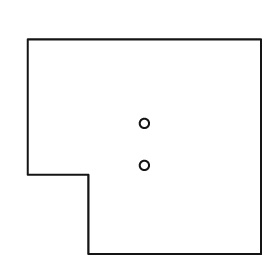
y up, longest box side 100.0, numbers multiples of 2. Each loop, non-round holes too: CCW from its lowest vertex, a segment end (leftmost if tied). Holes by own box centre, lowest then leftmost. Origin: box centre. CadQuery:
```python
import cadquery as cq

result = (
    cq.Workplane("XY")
    .moveTo(-24.0, -46.0)
    .lineTo(50.0, -46.0)
    .lineTo(50.0, 46.0)
    .lineTo(-50.0, 46.0)
    .lineTo(-50.0, -12.0)
    .lineTo(-24.0, -12.0)
    .close()
    .moveTo(0.0, -8.0)
    .circle(2.0)
    .moveTo(0.0, 10.0)
    .circle(2.0)
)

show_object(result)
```